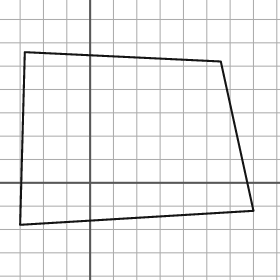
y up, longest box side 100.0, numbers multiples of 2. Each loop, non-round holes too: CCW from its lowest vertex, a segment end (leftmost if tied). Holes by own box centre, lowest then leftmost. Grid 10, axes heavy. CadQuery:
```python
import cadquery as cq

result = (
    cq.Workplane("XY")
    .moveTo(-30.0, -18.0)
    .lineTo(70.0, -12.0)
    .lineTo(56.0, 52.0)
    .lineTo(-28.0, 56.0)
    .close()
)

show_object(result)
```